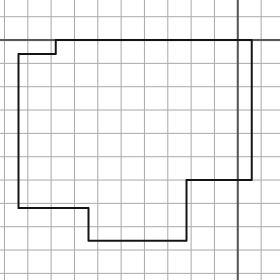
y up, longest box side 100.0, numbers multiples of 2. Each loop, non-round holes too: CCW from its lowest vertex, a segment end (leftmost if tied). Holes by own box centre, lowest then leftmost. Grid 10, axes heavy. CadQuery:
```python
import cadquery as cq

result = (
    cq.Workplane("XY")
    .moveTo(-64.0, -86.0)
    .lineTo(-22.0, -86.0)
    .lineTo(-22.0, -60.0)
    .lineTo(6.0, -60.0)
    .lineTo(6.0, 0.0)
    .lineTo(-78.0, 0.0)
    .lineTo(-78.0, -6.0)
    .lineTo(-94.0, -6.0)
    .lineTo(-94.0, -72.0)
    .lineTo(-64.0, -72.0)
    .close()
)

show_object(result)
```